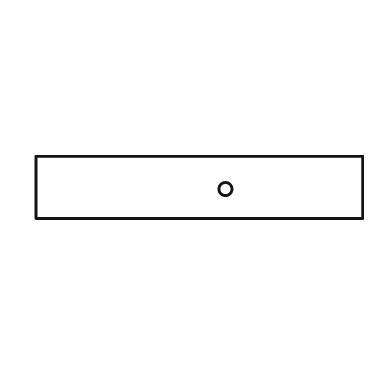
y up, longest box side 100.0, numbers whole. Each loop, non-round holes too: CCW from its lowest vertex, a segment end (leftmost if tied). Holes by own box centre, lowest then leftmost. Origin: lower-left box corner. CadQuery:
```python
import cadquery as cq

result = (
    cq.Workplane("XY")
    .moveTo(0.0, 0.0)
    .lineTo(100.0, 0.0)
    .lineTo(100.0, 19.0)
    .lineTo(0.0, 19.0)
    .close()
    .moveTo(58.0, 9.0)
    .circle(2.0)
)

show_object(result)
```